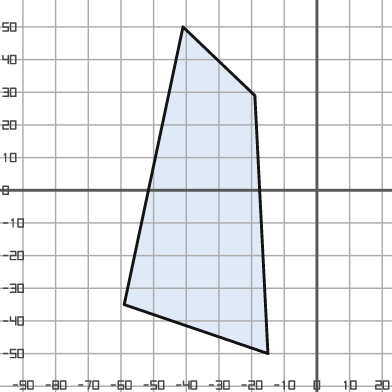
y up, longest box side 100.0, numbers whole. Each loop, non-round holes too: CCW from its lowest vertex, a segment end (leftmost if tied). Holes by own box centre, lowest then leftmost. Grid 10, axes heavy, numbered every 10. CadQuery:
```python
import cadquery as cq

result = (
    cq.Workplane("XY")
    .moveTo(-15.0, -50.0)
    .lineTo(-19.0, 29.0)
    .lineTo(-41.0, 50.0)
    .lineTo(-59.0, -35.0)
    .close()
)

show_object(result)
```